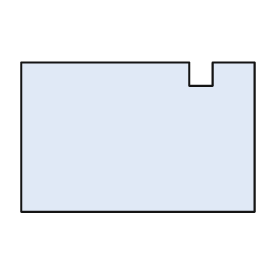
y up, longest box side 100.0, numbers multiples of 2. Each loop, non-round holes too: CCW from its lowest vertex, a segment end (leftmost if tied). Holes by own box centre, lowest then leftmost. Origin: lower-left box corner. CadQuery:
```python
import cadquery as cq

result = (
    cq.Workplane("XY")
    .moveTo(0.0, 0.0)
    .lineTo(100.0, 0.0)
    .lineTo(100.0, 64.0)
    .lineTo(82.0, 64.0)
    .lineTo(82.0, 54.0)
    .lineTo(72.0, 54.0)
    .lineTo(72.0, 64.0)
    .lineTo(0.0, 64.0)
    .close()
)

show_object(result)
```